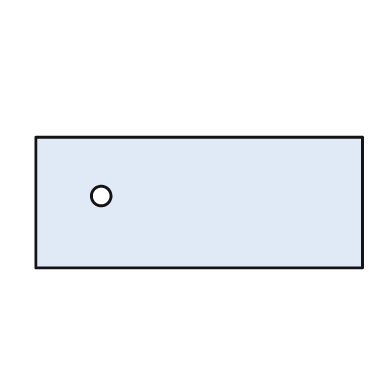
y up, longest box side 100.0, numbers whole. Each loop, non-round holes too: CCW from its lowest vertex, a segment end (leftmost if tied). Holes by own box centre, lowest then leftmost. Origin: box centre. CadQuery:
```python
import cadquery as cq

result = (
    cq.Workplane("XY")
    .moveTo(-50.0, -20.0)
    .lineTo(50.0, -20.0)
    .lineTo(50.0, 20.0)
    .lineTo(-50.0, 20.0)
    .close()
    .moveTo(-30.0, 2.0)
    .circle(3.0)
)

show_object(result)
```